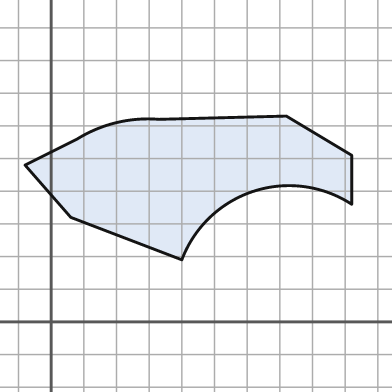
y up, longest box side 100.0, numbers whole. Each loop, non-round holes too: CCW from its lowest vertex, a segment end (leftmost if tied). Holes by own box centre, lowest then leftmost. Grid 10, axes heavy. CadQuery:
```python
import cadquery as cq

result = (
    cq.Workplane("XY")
    .moveTo(40.0, 19.0)
    .threePointArc((62.0, 40.0), (92.0, 36.0))
    .lineTo(92.0, 51.0)
    .lineTo(72.0, 63.0)
    .lineTo(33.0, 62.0)
    .threePointArc((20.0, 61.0), (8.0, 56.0))
    .lineTo(-8.0, 48.0)
    .lineTo(6.0, 32.0)
    .close()
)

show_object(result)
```